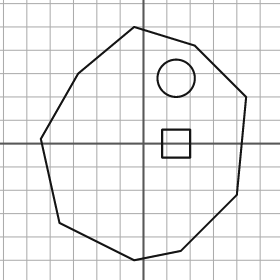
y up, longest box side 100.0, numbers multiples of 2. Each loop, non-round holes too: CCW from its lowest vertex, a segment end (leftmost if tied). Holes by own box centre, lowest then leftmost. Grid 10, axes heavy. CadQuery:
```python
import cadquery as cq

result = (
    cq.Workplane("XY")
    .moveTo(-4.0, -50.0)
    .lineTo(16.0, -46.0)
    .lineTo(40.0, -22.0)
    .lineTo(44.0, 20.0)
    .lineTo(22.0, 42.0)
    .lineTo(-4.0, 50.0)
    .lineTo(-28.0, 30.0)
    .lineTo(-44.0, 2.0)
    .lineTo(-36.0, -34.0)
    .close()
    .moveTo(8.0, -6.0)
    .lineTo(20.0, -6.0)
    .lineTo(20.0, 6.0)
    .lineTo(8.0, 6.0)
    .close()
    .moveTo(14.0, 28.0)
    .circle(8.0)
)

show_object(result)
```